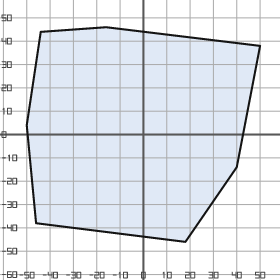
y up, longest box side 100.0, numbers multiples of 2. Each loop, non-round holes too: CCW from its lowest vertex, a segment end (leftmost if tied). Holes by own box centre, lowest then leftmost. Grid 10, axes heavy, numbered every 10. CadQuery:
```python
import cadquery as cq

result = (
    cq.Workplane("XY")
    .moveTo(18.0, -46.0)
    .lineTo(40.0, -14.0)
    .lineTo(50.0, 38.0)
    .lineTo(-16.0, 46.0)
    .lineTo(-44.0, 44.0)
    .lineTo(-50.0, 4.0)
    .lineTo(-46.0, -38.0)
    .close()
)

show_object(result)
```